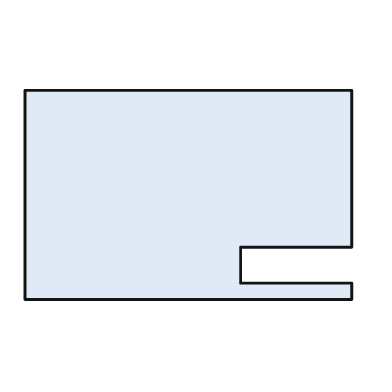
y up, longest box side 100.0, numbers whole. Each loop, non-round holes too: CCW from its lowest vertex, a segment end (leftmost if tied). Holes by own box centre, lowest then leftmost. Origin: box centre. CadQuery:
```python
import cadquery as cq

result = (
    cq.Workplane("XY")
    .moveTo(-50.0, -32.0)
    .lineTo(50.0, -32.0)
    .lineTo(50.0, -27.0)
    .lineTo(16.0, -27.0)
    .lineTo(16.0, -16.0)
    .lineTo(50.0, -16.0)
    .lineTo(50.0, 32.0)
    .lineTo(-50.0, 32.0)
    .close()
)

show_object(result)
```